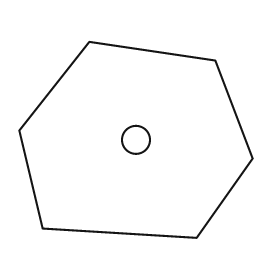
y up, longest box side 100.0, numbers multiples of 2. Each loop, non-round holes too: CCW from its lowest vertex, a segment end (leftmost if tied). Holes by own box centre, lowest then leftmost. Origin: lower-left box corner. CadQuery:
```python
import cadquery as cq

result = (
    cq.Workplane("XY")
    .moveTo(76.0, 0.0)
    .lineTo(100.0, 34.0)
    .lineTo(84.0, 76.0)
    .lineTo(30.0, 84.0)
    .lineTo(0.0, 46.0)
    .lineTo(10.0, 4.0)
    .close()
    .moveTo(50.0, 42.0)
    .circle(6.0)
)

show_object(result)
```